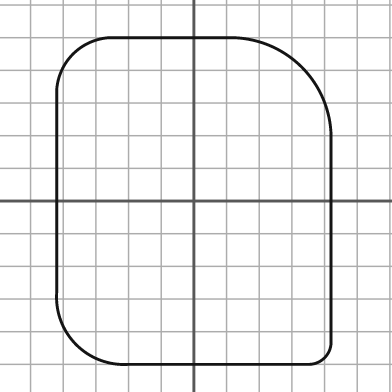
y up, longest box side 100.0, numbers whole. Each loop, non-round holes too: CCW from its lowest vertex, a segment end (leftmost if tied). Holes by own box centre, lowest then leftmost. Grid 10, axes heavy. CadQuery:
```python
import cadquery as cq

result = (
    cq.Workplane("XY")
    .moveTo(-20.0, -50.0)
    .lineTo(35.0, -50.0)
    .threePointArc((40.0, -48.0), (42.0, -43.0))
    .lineTo(42.0, 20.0)
    .threePointArc((33.0, 41.0), (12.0, 50.0))
    .lineTo(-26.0, 50.0)
    .threePointArc((-37.0, 45.0), (-42.0, 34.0))
    .lineTo(-42.0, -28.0)
    .threePointArc((-36.0, -44.0), (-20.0, -50.0))
    .close()
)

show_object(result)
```